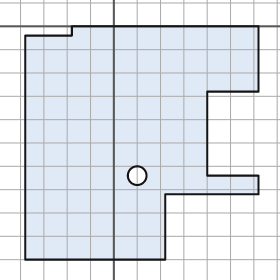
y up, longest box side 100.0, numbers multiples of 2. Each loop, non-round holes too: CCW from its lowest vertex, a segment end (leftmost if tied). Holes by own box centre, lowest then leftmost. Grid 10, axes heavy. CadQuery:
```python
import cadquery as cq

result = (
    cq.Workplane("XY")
    .moveTo(-38.0, -100.0)
    .lineTo(22.0, -100.0)
    .lineTo(22.0, -72.0)
    .lineTo(62.0, -72.0)
    .lineTo(62.0, -64.0)
    .lineTo(40.0, -64.0)
    .lineTo(40.0, -28.0)
    .lineTo(62.0, -28.0)
    .lineTo(62.0, 0.0)
    .lineTo(-18.0, 0.0)
    .lineTo(-18.0, -4.0)
    .lineTo(-38.0, -4.0)
    .close()
    .moveTo(10.0, -64.0)
    .circle(4.0)
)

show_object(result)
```